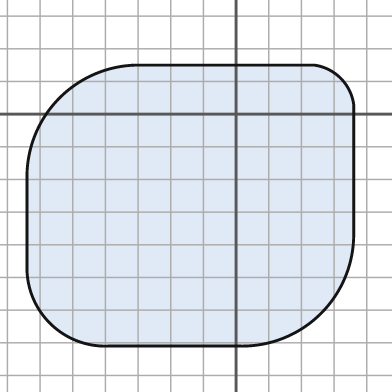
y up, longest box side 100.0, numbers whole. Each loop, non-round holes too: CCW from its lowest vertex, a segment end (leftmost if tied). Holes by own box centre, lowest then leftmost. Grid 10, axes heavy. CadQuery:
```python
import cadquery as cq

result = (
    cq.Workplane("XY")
    .moveTo(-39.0, -71.0)
    .lineTo(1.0, -71.0)
    .threePointArc((26.0, -61.0), (36.0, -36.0))
    .lineTo(36.0, 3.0)
    .threePointArc((32.0, 11.0), (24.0, 15.0))
    .lineTo(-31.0, 15.0)
    .threePointArc((-54.0, 5.0), (-64.0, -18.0))
    .lineTo(-64.0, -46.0)
    .threePointArc((-57.0, -64.0), (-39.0, -71.0))
    .close()
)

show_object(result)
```